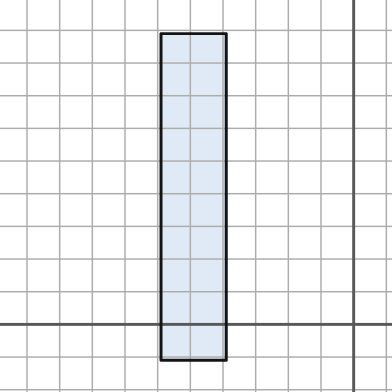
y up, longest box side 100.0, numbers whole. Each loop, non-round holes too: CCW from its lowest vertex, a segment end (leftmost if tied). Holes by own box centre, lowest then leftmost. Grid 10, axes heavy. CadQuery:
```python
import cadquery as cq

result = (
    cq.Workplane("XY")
    .moveTo(-59.0, -11.0)
    .lineTo(-39.0, -11.0)
    .lineTo(-39.0, 89.0)
    .lineTo(-59.0, 89.0)
    .close()
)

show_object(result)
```